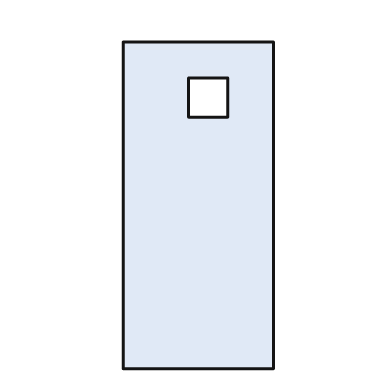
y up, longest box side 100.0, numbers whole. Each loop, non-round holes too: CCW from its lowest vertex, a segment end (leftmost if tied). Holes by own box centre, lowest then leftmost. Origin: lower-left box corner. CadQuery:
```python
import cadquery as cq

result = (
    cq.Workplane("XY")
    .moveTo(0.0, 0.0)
    .lineTo(46.0, 0.0)
    .lineTo(46.0, 100.0)
    .lineTo(0.0, 100.0)
    .close()
    .moveTo(20.0, 77.0)
    .lineTo(32.0, 77.0)
    .lineTo(32.0, 89.0)
    .lineTo(20.0, 89.0)
    .close()
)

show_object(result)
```